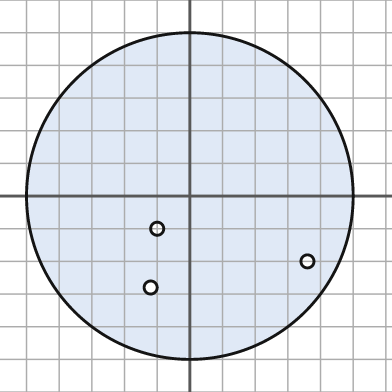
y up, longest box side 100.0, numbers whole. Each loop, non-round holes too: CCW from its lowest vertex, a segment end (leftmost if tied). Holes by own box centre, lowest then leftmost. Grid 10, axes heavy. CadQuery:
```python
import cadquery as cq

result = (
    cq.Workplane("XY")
    .moveTo(0.0, 0.0)
    .circle(50.0)
    .moveTo(-12.0, -28.0)
    .circle(2.0)
    .moveTo(36.0, -20.0)
    .circle(2.0)
    .moveTo(-10.0, -10.0)
    .circle(2.0)
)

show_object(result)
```